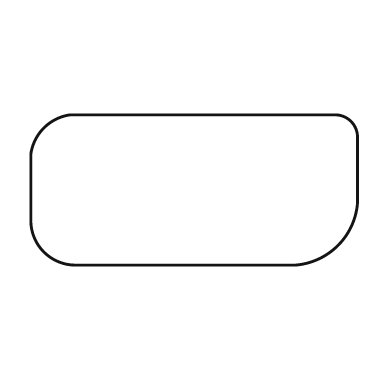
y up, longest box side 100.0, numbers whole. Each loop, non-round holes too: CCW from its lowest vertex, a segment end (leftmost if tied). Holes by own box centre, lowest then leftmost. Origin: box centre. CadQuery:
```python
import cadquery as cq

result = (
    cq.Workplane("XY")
    .moveTo(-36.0, -23.0)
    .lineTo(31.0, -23.0)
    .threePointArc((44.0, -17.0), (50.0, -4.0))
    .lineTo(50.0, 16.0)
    .threePointArc((48.0, 21.0), (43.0, 23.0))
    .lineTo(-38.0, 23.0)
    .threePointArc((-46.0, 19.0), (-50.0, 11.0))
    .lineTo(-50.0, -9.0)
    .threePointArc((-46.0, -19.0), (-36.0, -23.0))
    .close()
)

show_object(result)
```